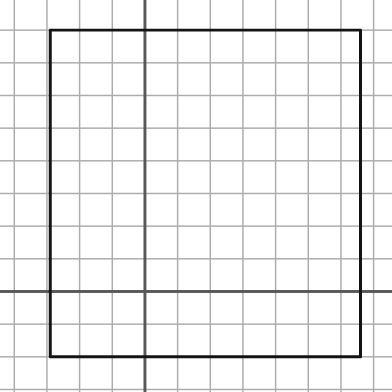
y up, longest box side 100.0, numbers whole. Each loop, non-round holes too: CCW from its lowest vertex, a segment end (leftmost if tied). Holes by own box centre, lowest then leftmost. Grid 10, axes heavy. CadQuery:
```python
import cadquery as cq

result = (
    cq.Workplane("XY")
    .moveTo(-29.0, -20.0)
    .lineTo(66.0, -20.0)
    .lineTo(66.0, 80.0)
    .lineTo(-29.0, 80.0)
    .close()
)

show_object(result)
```